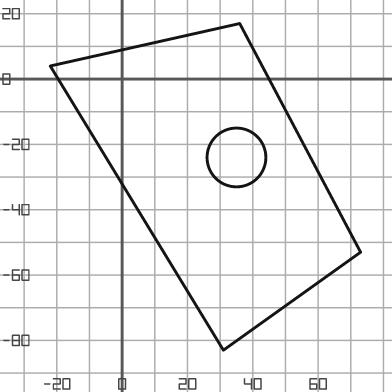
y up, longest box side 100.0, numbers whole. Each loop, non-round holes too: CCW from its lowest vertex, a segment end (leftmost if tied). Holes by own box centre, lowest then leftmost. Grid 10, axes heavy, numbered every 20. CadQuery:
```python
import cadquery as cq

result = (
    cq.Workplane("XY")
    .moveTo(31.0, -83.0)
    .lineTo(73.0, -53.0)
    .lineTo(36.0, 17.0)
    .lineTo(-22.0, 4.0)
    .close()
    .moveTo(35.0, -24.0)
    .circle(9.0)
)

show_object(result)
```